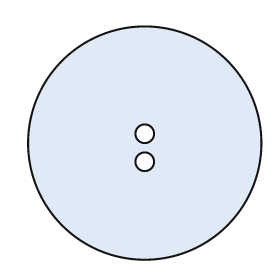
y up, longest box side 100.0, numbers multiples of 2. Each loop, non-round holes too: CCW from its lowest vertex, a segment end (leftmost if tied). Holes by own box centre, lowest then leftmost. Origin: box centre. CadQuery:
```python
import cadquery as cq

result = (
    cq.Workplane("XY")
    .moveTo(0.0, 0.0)
    .circle(50.0)
    .moveTo(0.0, -8.0)
    .circle(4.0)
    .moveTo(0.0, 4.0)
    .circle(4.0)
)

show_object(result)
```